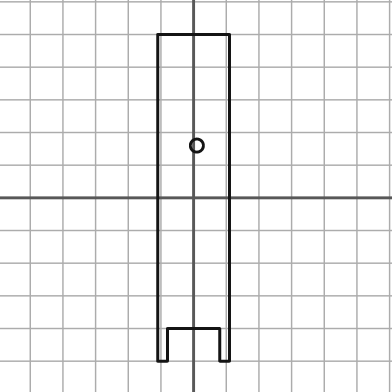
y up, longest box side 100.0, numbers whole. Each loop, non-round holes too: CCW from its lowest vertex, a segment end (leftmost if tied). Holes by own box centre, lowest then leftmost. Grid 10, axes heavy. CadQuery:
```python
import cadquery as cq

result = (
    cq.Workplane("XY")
    .moveTo(-11.0, -50.0)
    .lineTo(-8.0, -50.0)
    .lineTo(-8.0, -40.0)
    .lineTo(8.0, -40.0)
    .lineTo(8.0, -50.0)
    .lineTo(11.0, -50.0)
    .lineTo(11.0, 50.0)
    .lineTo(-11.0, 50.0)
    .close()
    .moveTo(1.0, 16.0)
    .circle(2.0)
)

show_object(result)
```